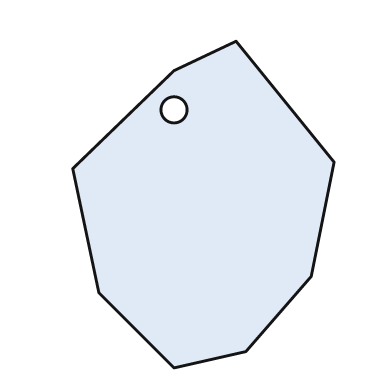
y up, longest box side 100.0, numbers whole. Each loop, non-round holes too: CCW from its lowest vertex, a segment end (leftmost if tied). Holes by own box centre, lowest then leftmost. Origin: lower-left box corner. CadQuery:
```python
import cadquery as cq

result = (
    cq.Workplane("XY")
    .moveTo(31.0, 0.0)
    .lineTo(53.0, 5.0)
    .lineTo(73.0, 28.0)
    .lineTo(80.0, 63.0)
    .lineTo(50.0, 100.0)
    .lineTo(31.0, 91.0)
    .lineTo(0.0, 61.0)
    .lineTo(8.0, 23.0)
    .close()
    .moveTo(31.0, 79.0)
    .circle(4.0)
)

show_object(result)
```